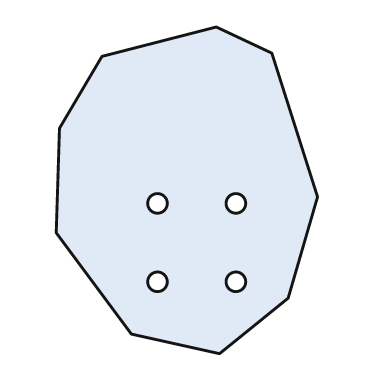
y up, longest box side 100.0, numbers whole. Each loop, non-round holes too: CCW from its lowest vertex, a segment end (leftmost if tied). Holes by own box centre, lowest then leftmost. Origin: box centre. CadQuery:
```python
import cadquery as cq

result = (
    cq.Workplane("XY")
    .moveTo(10.0, -50.0)
    .lineTo(31.0, -33.0)
    .lineTo(40.0, -2.0)
    .lineTo(26.0, 42.0)
    .lineTo(9.0, 50.0)
    .lineTo(-26.0, 41.0)
    .lineTo(-39.0, 19.0)
    .lineTo(-40.0, -13.0)
    .lineTo(-17.0, -44.0)
    .close()
    .moveTo(-9.0, -28.0)
    .circle(3.0)
    .moveTo(15.0, -28.0)
    .circle(3.0)
    .moveTo(-9.0, -4.0)
    .circle(3.0)
    .moveTo(15.0, -4.0)
    .circle(3.0)
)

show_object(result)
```